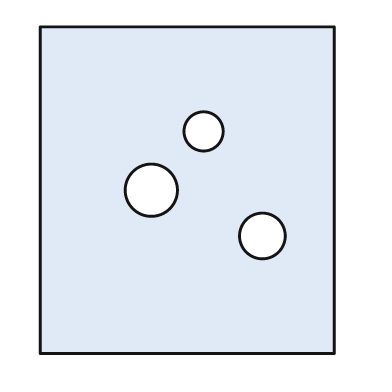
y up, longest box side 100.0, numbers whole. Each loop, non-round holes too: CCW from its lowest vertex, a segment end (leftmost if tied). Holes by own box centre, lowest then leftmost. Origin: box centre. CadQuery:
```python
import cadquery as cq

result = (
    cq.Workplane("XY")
    .moveTo(-45.0, -50.0)
    .lineTo(45.0, -50.0)
    .lineTo(45.0, 50.0)
    .lineTo(-45.0, 50.0)
    .close()
    .moveTo(23.0, -14.0)
    .circle(7.0)
    .moveTo(-11.0, 0.0)
    .circle(8.0)
    .moveTo(5.0, 18.0)
    .circle(6.0)
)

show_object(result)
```